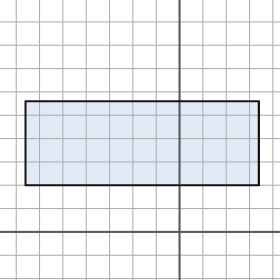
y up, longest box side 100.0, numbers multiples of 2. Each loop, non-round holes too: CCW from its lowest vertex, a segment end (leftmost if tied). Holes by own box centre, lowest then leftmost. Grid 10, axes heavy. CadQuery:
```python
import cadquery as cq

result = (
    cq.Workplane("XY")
    .moveTo(-66.0, 20.0)
    .lineTo(34.0, 20.0)
    .lineTo(34.0, 56.0)
    .lineTo(-66.0, 56.0)
    .close()
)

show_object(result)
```